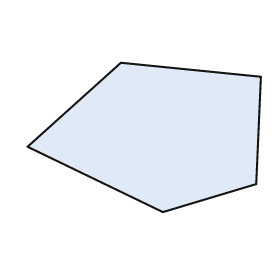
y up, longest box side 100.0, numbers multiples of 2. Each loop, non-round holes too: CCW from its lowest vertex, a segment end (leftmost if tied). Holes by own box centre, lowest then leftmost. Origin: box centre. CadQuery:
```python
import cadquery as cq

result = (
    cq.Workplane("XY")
    .moveTo(8.0, -32.0)
    .lineTo(48.0, -20.0)
    .lineTo(50.0, 26.0)
    .lineTo(-10.0, 32.0)
    .lineTo(-50.0, -4.0)
    .close()
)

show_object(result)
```